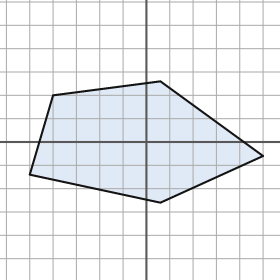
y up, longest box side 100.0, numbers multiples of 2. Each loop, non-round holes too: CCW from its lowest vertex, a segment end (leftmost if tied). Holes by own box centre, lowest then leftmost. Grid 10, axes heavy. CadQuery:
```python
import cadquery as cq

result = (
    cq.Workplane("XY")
    .moveTo(6.0, -26.0)
    .lineTo(50.0, -6.0)
    .lineTo(6.0, 26.0)
    .lineTo(-40.0, 20.0)
    .lineTo(-50.0, -14.0)
    .close()
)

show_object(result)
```